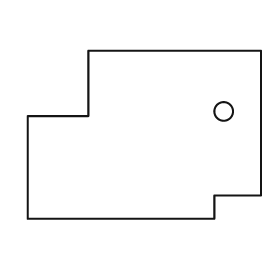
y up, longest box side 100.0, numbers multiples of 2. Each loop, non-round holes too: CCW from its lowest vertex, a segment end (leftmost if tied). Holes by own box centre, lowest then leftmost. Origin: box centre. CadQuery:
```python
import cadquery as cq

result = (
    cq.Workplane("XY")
    .moveTo(-50.0, -36.0)
    .lineTo(30.0, -36.0)
    .lineTo(30.0, -26.0)
    .lineTo(50.0, -26.0)
    .lineTo(50.0, 36.0)
    .lineTo(-24.0, 36.0)
    .lineTo(-24.0, 8.0)
    .lineTo(-50.0, 8.0)
    .close()
    .moveTo(34.0, 10.0)
    .circle(4.0)
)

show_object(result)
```